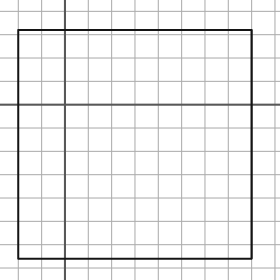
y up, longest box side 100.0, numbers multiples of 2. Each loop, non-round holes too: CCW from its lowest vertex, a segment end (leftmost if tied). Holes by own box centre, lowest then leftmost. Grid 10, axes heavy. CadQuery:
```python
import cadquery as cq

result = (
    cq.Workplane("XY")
    .moveTo(-20.0, -66.0)
    .lineTo(80.0, -66.0)
    .lineTo(80.0, 32.0)
    .lineTo(-20.0, 32.0)
    .close()
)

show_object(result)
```